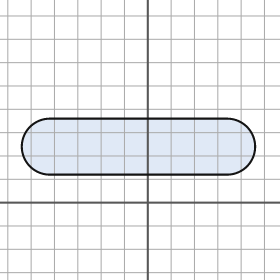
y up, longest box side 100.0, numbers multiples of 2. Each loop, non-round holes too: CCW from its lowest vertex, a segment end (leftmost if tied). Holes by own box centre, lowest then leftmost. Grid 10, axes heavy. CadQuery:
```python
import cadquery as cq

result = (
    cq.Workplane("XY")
    .moveTo(-42.0, 12.0)
    .lineTo(34.0, 12.0)
    .threePointArc((46.0, 24.0), (34.0, 36.0))
    .lineTo(-42.0, 36.0)
    .threePointArc((-54.0, 24.0), (-42.0, 12.0))
    .close()
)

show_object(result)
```